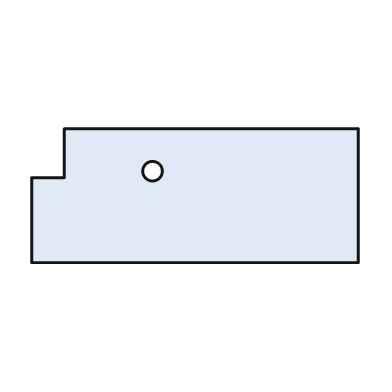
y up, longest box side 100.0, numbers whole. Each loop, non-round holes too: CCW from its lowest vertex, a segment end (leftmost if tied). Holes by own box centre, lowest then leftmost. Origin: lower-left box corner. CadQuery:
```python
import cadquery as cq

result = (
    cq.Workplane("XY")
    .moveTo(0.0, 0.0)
    .lineTo(100.0, 0.0)
    .lineTo(100.0, 41.0)
    .lineTo(10.0, 41.0)
    .lineTo(10.0, 26.0)
    .lineTo(0.0, 26.0)
    .close()
    .moveTo(37.0, 28.0)
    .circle(3.0)
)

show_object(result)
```